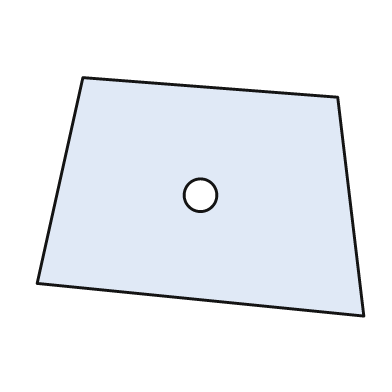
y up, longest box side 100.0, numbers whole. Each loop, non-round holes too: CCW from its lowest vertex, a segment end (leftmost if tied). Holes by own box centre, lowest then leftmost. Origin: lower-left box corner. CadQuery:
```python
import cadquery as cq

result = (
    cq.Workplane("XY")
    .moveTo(100.0, 0.0)
    .lineTo(92.0, 67.0)
    .lineTo(14.0, 73.0)
    .lineTo(0.0, 10.0)
    .close()
    .moveTo(50.0, 37.0)
    .circle(5.0)
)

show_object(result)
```